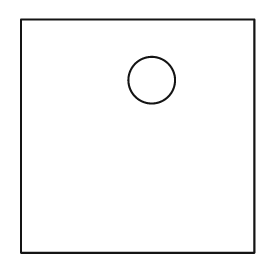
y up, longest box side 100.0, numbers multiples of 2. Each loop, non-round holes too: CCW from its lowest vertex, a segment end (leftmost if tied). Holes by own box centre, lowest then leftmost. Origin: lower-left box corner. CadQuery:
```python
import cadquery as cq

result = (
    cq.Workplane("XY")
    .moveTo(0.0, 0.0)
    .lineTo(100.0, 0.0)
    .lineTo(100.0, 100.0)
    .lineTo(0.0, 100.0)
    .close()
    .moveTo(56.0, 74.0)
    .circle(10.0)
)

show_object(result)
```